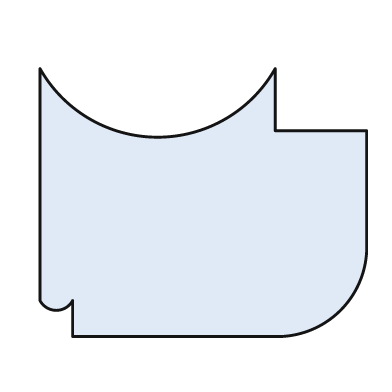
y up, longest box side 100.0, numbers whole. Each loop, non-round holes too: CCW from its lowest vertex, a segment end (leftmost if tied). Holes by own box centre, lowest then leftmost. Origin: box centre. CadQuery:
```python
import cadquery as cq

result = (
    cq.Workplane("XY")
    .moveTo(-40.0, -41.0)
    .lineTo(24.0, -41.0)
    .threePointArc((42.0, -33.0), (50.0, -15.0))
    .lineTo(50.0, 22.0)
    .lineTo(22.0, 22.0)
    .lineTo(22.0, 41.0)
    .threePointArc((-14.0, 20.0), (-50.0, 41.0))
    .lineTo(-50.0, -30.0)
    .threePointArc((-45.0, -33.0), (-40.0, -30.0))
    .close()
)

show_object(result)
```